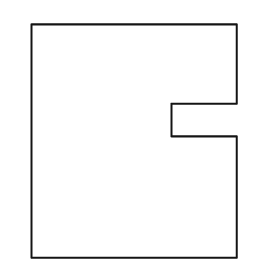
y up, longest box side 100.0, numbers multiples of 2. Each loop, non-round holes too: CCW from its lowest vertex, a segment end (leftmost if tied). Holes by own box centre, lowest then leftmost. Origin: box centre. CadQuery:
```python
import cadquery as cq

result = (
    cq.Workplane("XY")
    .moveTo(-44.0, -50.0)
    .lineTo(44.0, -50.0)
    .lineTo(44.0, 2.0)
    .lineTo(16.0, 2.0)
    .lineTo(16.0, 16.0)
    .lineTo(44.0, 16.0)
    .lineTo(44.0, 50.0)
    .lineTo(-44.0, 50.0)
    .close()
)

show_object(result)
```